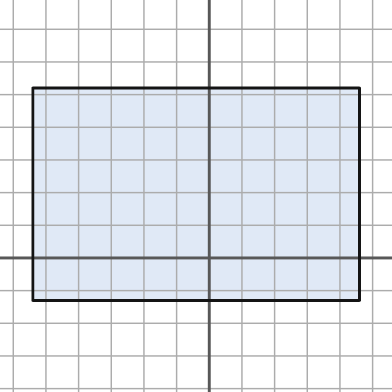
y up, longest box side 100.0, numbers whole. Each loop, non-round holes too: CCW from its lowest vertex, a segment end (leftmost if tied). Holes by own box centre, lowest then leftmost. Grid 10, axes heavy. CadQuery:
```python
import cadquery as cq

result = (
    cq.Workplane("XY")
    .moveTo(-54.0, -13.0)
    .lineTo(46.0, -13.0)
    .lineTo(46.0, 52.0)
    .lineTo(-54.0, 52.0)
    .close()
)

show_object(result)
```